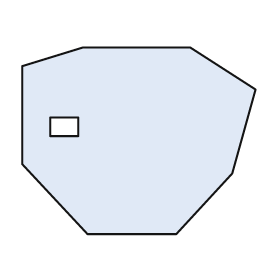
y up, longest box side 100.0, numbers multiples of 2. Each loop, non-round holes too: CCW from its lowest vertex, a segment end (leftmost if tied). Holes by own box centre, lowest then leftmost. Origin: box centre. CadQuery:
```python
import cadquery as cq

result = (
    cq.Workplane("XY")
    .moveTo(-22.0, -40.0)
    .lineTo(16.0, -40.0)
    .lineTo(40.0, -14.0)
    .lineTo(50.0, 22.0)
    .lineTo(22.0, 40.0)
    .lineTo(-24.0, 40.0)
    .lineTo(-50.0, 32.0)
    .lineTo(-50.0, -10.0)
    .close()
    .moveTo(-38.0, 2.0)
    .lineTo(-26.0, 2.0)
    .lineTo(-26.0, 10.0)
    .lineTo(-38.0, 10.0)
    .close()
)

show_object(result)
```